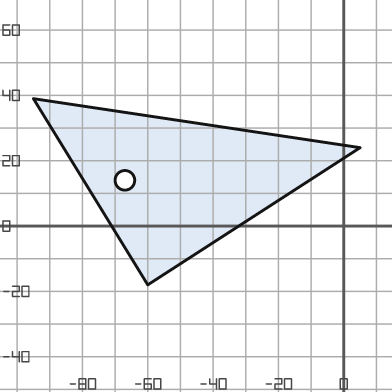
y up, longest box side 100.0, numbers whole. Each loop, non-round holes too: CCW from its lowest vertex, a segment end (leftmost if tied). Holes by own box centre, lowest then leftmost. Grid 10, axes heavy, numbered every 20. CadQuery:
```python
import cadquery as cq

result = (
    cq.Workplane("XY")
    .moveTo(-60.0, -18.0)
    .lineTo(5.0, 24.0)
    .lineTo(-95.0, 39.0)
    .close()
    .moveTo(-67.0, 14.0)
    .circle(3.0)
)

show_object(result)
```